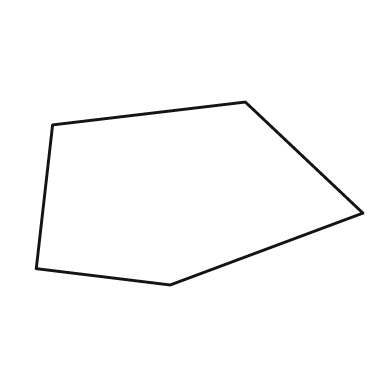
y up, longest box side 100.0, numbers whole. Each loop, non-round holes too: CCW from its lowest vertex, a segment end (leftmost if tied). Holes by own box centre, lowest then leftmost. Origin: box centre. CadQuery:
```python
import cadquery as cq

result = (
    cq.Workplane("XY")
    .moveTo(-9.0, -28.0)
    .lineTo(50.0, -6.0)
    .lineTo(14.0, 28.0)
    .lineTo(-45.0, 21.0)
    .lineTo(-50.0, -23.0)
    .close()
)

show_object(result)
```